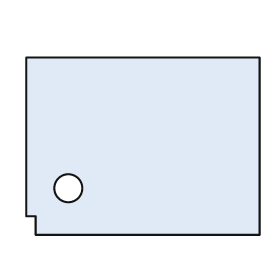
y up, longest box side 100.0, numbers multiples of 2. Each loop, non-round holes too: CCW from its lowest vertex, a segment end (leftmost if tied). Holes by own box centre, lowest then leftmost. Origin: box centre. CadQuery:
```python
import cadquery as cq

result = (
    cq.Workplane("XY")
    .moveTo(-46.0, -38.0)
    .lineTo(50.0, -38.0)
    .lineTo(50.0, 38.0)
    .lineTo(-50.0, 38.0)
    .lineTo(-50.0, -30.0)
    .lineTo(-46.0, -30.0)
    .close()
    .moveTo(-32.0, -18.0)
    .circle(6.0)
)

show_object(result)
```